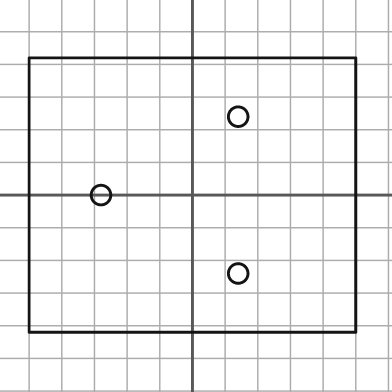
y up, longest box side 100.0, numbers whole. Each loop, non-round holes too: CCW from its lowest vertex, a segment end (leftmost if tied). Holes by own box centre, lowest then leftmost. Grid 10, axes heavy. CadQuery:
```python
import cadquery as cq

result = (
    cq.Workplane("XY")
    .moveTo(-50.0, -42.0)
    .lineTo(50.0, -42.0)
    .lineTo(50.0, 42.0)
    .lineTo(-50.0, 42.0)
    .close()
    .moveTo(14.0, -24.0)
    .circle(3.0)
    .moveTo(-28.0, 0.0)
    .circle(3.0)
    .moveTo(14.0, 24.0)
    .circle(3.0)
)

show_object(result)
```